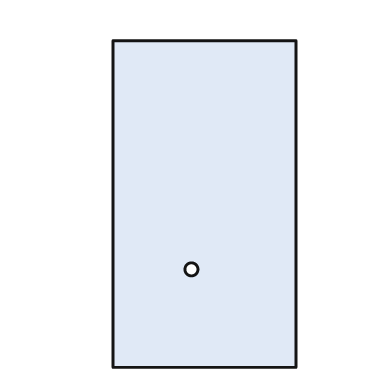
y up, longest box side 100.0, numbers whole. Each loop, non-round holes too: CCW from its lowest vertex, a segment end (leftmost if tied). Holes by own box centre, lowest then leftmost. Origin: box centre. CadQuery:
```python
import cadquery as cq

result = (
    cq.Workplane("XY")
    .moveTo(-28.0, -50.0)
    .lineTo(28.0, -50.0)
    .lineTo(28.0, 50.0)
    .lineTo(-28.0, 50.0)
    .close()
    .moveTo(-4.0, -20.0)
    .circle(2.0)
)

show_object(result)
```